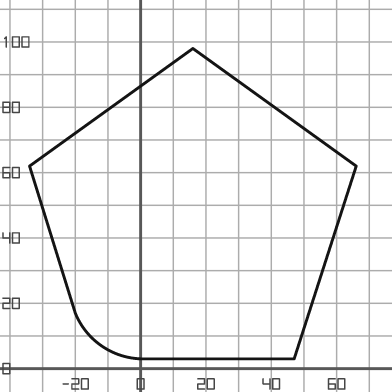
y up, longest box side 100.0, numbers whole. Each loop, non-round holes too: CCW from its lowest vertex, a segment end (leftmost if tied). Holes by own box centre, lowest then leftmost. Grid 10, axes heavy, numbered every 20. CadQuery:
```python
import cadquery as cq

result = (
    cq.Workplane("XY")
    .moveTo(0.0, 3.0)
    .lineTo(47.0, 3.0)
    .lineTo(66.0, 62.0)
    .lineTo(16.0, 98.0)
    .lineTo(-34.0, 62.0)
    .lineTo(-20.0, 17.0)
    .threePointArc((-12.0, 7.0), (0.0, 3.0))
    .close()
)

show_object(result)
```